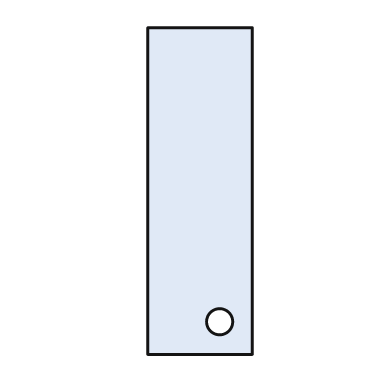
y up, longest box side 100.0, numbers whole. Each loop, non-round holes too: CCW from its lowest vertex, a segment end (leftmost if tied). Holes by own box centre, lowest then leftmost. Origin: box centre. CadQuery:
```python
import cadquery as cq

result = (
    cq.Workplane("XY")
    .moveTo(-16.0, -50.0)
    .lineTo(16.0, -50.0)
    .lineTo(16.0, 50.0)
    .lineTo(-16.0, 50.0)
    .close()
    .moveTo(6.0, -40.0)
    .circle(4.0)
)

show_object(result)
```